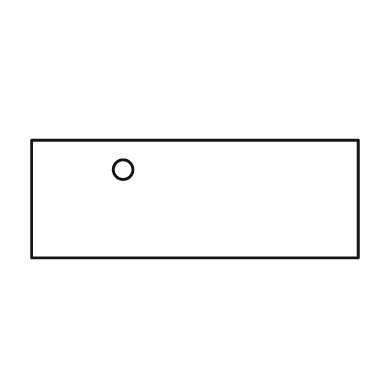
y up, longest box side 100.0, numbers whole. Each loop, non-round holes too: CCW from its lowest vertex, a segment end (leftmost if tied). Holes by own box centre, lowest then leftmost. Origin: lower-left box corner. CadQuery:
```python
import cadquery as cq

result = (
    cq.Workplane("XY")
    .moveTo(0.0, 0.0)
    .lineTo(100.0, 0.0)
    .lineTo(100.0, 36.0)
    .lineTo(0.0, 36.0)
    .close()
    .moveTo(28.0, 27.0)
    .circle(3.0)
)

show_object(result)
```